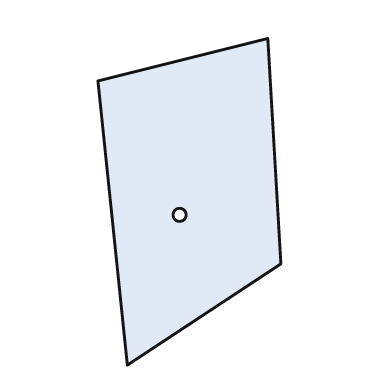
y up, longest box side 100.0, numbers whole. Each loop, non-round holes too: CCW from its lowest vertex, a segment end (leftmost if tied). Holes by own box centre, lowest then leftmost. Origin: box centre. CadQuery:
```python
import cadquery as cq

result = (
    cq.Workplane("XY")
    .moveTo(-19.0, -50.0)
    .lineTo(28.0, -19.0)
    .lineTo(24.0, 50.0)
    .lineTo(-28.0, 37.0)
    .close()
    .moveTo(-3.0, -4.0)
    .circle(2.0)
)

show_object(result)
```